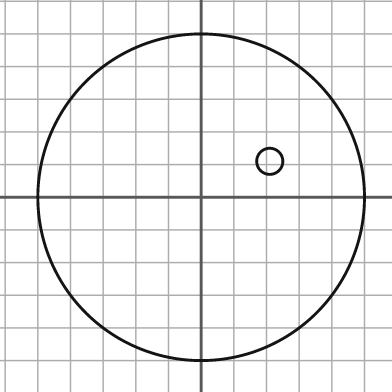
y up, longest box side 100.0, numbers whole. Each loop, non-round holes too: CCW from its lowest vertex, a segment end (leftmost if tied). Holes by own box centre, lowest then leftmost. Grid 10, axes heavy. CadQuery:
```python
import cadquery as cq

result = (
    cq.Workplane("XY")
    .moveTo(0.0, 0.0)
    .circle(50.0)
    .moveTo(21.0, 11.0)
    .circle(4.0)
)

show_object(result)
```